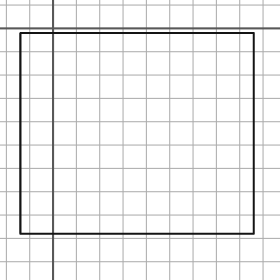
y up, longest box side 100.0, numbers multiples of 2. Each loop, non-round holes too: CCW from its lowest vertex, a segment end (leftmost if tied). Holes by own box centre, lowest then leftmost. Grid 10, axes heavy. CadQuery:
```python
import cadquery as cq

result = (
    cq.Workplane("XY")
    .moveTo(-14.0, -88.0)
    .lineTo(86.0, -88.0)
    .lineTo(86.0, -2.0)
    .lineTo(-14.0, -2.0)
    .close()
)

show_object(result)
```